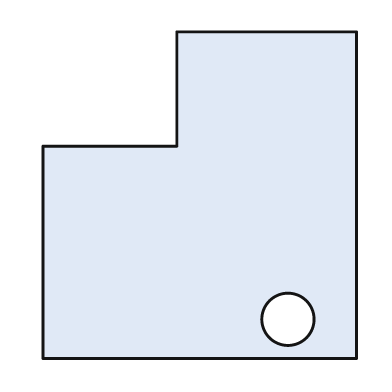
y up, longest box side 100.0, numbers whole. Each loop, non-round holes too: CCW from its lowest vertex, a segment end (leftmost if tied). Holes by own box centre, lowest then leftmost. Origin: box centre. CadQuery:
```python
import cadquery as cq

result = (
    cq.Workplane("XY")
    .moveTo(-48.0, -50.0)
    .lineTo(48.0, -50.0)
    .lineTo(48.0, 50.0)
    .lineTo(-7.0, 50.0)
    .lineTo(-7.0, 15.0)
    .lineTo(-48.0, 15.0)
    .close()
    .moveTo(27.0, -38.0)
    .circle(8.0)
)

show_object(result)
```